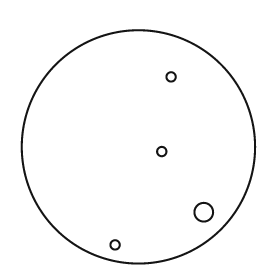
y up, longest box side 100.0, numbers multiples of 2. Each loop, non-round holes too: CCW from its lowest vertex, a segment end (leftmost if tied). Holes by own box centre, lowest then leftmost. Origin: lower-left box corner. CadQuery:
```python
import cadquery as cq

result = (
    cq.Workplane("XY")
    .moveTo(50.0, 50.0)
    .circle(50.0)
    .moveTo(40.0, 8.0)
    .circle(2.0)
    .moveTo(78.0, 22.0)
    .circle(4.0)
    .moveTo(60.0, 48.0)
    .circle(2.0)
    .moveTo(64.0, 80.0)
    .circle(2.0)
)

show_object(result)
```